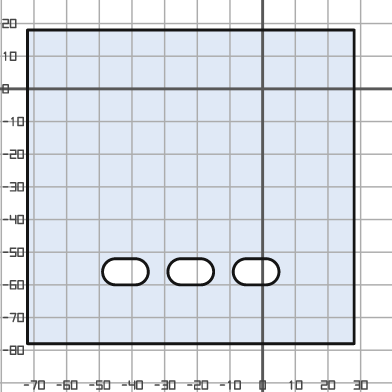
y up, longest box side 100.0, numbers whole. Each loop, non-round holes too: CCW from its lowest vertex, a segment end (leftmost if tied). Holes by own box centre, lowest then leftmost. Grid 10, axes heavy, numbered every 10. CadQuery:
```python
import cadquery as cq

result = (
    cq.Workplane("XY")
    .moveTo(-72.0, -78.0)
    .lineTo(28.0, -78.0)
    .lineTo(28.0, 18.0)
    .lineTo(-72.0, 18.0)
    .close()
    .moveTo(-45.0, -60.0)
    .lineTo(-39.0, -60.0)
    .threePointArc((-35.0, -56.0), (-39.0, -52.0))
    .lineTo(-45.0, -52.0)
    .threePointArc((-49.0, -56.0), (-45.0, -60.0))
    .close()
    .moveTo(-25.0, -60.0)
    .lineTo(-19.0, -60.0)
    .threePointArc((-15.0, -56.0), (-19.0, -52.0))
    .lineTo(-25.0, -52.0)
    .threePointArc((-29.0, -56.0), (-25.0, -60.0))
    .close()
    .moveTo(-5.0, -60.0)
    .lineTo(1.0, -60.0)
    .threePointArc((5.0, -56.0), (1.0, -52.0))
    .lineTo(-5.0, -52.0)
    .threePointArc((-9.0, -56.0), (-5.0, -60.0))
    .close()
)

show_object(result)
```